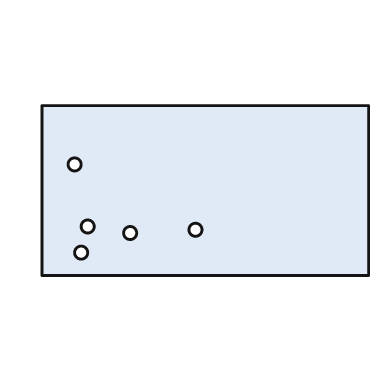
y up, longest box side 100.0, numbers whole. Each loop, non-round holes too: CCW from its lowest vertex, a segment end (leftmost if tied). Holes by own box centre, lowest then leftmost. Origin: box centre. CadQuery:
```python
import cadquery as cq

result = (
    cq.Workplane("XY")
    .moveTo(-50.0, -26.0)
    .lineTo(50.0, -26.0)
    .lineTo(50.0, 26.0)
    .lineTo(-50.0, 26.0)
    .close()
    .moveTo(-38.0, -19.0)
    .circle(2.0)
    .moveTo(-23.0, -13.0)
    .circle(2.0)
    .moveTo(-3.0, -12.0)
    .circle(2.0)
    .moveTo(-36.0, -11.0)
    .circle(2.0)
    .moveTo(-40.0, 8.0)
    .circle(2.0)
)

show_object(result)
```